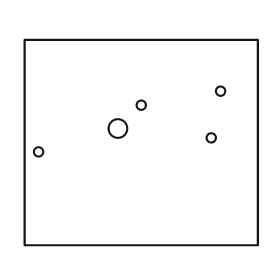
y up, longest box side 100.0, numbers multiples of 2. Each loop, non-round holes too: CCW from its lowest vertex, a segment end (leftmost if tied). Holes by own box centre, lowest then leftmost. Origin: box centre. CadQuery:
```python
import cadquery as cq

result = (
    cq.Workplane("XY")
    .moveTo(-50.0, -44.0)
    .lineTo(50.0, -44.0)
    .lineTo(50.0, 44.0)
    .lineTo(-50.0, 44.0)
    .close()
    .moveTo(-44.0, -4.0)
    .circle(2.0)
    .moveTo(30.0, 2.0)
    .circle(2.0)
    .moveTo(-10.0, 6.0)
    .circle(4.0)
    .moveTo(0.0, 16.0)
    .circle(2.0)
    .moveTo(34.0, 22.0)
    .circle(2.0)
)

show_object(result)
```